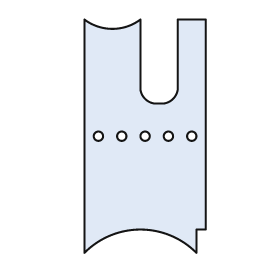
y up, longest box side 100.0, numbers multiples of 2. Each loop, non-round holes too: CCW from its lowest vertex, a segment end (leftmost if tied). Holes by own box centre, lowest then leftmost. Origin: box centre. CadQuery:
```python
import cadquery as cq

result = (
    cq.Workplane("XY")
    .moveTo(-26.0, -50.0)
    .threePointArc((-2.0, -40.0), (22.0, -50.0))
    .lineTo(22.0, -40.0)
    .lineTo(26.0, -40.0)
    .lineTo(26.0, 50.0)
    .lineTo(14.0, 50.0)
    .lineTo(14.0, 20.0)
    .threePointArc((12.0, 16.0), (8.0, 14.0))
    .lineTo(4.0, 14.0)
    .threePointArc((0.0, 16.0), (-2.0, 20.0))
    .lineTo(-2.0, 50.0)
    .threePointArc((-14.0, 46.0), (-26.0, 50.0))
    .close()
    .moveTo(-20.0, 0.0)
    .circle(2.0)
    .moveTo(-10.0, 0.0)
    .circle(2.0)
    .moveTo(0.0, 0.0)
    .circle(2.0)
    .moveTo(10.0, 0.0)
    .circle(2.0)
    .moveTo(20.0, 0.0)
    .circle(2.0)
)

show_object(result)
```